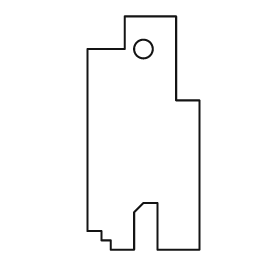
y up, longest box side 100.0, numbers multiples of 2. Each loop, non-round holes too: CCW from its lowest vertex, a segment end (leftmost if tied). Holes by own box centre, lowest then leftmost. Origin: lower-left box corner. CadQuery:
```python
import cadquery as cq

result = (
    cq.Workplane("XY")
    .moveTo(10.0, 0.0)
    .lineTo(20.0, 0.0)
    .lineTo(20.0, 16.0)
    .lineTo(24.0, 20.0)
    .lineTo(30.0, 20.0)
    .lineTo(30.0, 0.0)
    .lineTo(48.0, 0.0)
    .lineTo(48.0, 64.0)
    .lineTo(38.0, 64.0)
    .lineTo(38.0, 100.0)
    .lineTo(16.0, 100.0)
    .lineTo(16.0, 86.0)
    .lineTo(0.0, 86.0)
    .lineTo(0.0, 8.0)
    .lineTo(6.0, 8.0)
    .lineTo(6.0, 4.0)
    .lineTo(10.0, 4.0)
    .close()
    .moveTo(24.0, 86.0)
    .circle(4.0)
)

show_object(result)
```